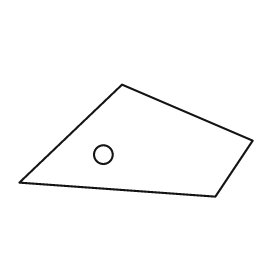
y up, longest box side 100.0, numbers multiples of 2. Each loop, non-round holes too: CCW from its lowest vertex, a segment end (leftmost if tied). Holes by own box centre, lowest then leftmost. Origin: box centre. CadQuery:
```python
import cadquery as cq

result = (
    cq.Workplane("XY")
    .moveTo(34.0, -24.0)
    .lineTo(50.0, 0.0)
    .lineTo(-6.0, 24.0)
    .lineTo(-50.0, -18.0)
    .close()
    .moveTo(-14.0, -6.0)
    .circle(4.0)
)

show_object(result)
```